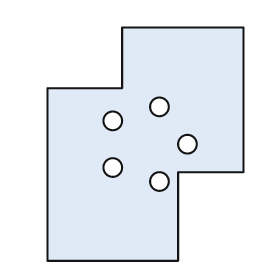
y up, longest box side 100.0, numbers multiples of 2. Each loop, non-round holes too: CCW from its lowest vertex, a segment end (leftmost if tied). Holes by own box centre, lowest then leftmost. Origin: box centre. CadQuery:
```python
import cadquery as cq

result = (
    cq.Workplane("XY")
    .moveTo(-42.0, -50.0)
    .lineTo(14.0, -50.0)
    .lineTo(14.0, -12.0)
    .lineTo(42.0, -12.0)
    .lineTo(42.0, 50.0)
    .lineTo(-10.0, 50.0)
    .lineTo(-10.0, 24.0)
    .lineTo(-42.0, 24.0)
    .close()
    .moveTo(6.0, -16.0)
    .circle(4.0)
    .moveTo(-14.0, -10.0)
    .circle(4.0)
    .moveTo(18.0, 0.0)
    .circle(4.0)
    .moveTo(-14.0, 10.0)
    .circle(4.0)
    .moveTo(6.0, 16.0)
    .circle(4.0)
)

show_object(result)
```